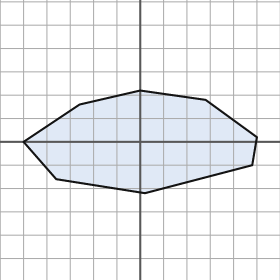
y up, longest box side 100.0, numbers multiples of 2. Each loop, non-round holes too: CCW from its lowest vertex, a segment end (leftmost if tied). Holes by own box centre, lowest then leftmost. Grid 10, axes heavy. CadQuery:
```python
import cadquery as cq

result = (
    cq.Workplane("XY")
    .moveTo(2.0, -22.0)
    .lineTo(48.0, -10.0)
    .lineTo(50.0, 2.0)
    .lineTo(28.0, 18.0)
    .lineTo(0.0, 22.0)
    .lineTo(-26.0, 16.0)
    .lineTo(-50.0, 0.0)
    .lineTo(-36.0, -16.0)
    .close()
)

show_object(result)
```